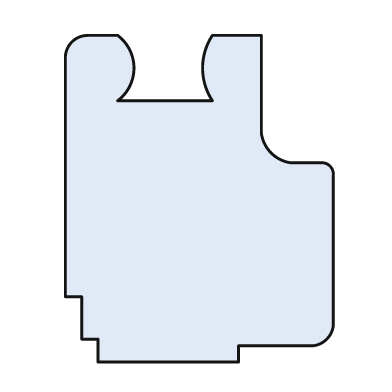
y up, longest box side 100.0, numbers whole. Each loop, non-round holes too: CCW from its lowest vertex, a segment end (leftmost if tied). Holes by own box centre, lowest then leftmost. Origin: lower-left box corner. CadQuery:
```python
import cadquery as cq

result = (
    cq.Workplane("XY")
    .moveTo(10.0, 0.0)
    .lineTo(53.0, 0.0)
    .lineTo(53.0, 5.0)
    .lineTo(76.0, 5.0)
    .threePointArc((80.0, 7.0), (82.0, 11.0))
    .lineTo(82.0, 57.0)
    .threePointArc((81.0, 60.0), (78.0, 61.0))
    .lineTo(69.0, 61.0)
    .threePointArc((63.0, 64.0), (60.0, 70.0))
    .lineTo(60.0, 100.0)
    .lineTo(45.0, 100.0)
    .threePointArc((42.0, 90.0), (45.0, 80.0))
    .lineTo(16.0, 80.0)
    .threePointArc((21.0, 90.0), (16.0, 100.0))
    .lineTo(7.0, 100.0)
    .threePointArc((2.0, 98.0), (0.0, 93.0))
    .lineTo(0.0, 20.0)
    .lineTo(5.0, 20.0)
    .lineTo(5.0, 7.0)
    .lineTo(10.0, 7.0)
    .close()
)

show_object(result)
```